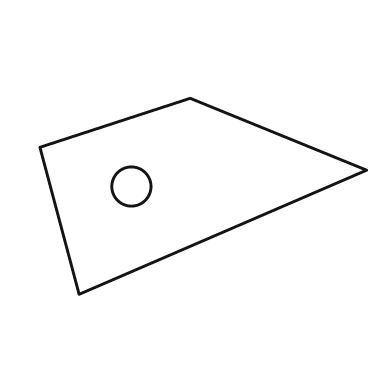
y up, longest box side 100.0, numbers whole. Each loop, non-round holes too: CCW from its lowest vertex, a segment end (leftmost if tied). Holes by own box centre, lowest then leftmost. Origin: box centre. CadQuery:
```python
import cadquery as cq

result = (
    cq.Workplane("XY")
    .moveTo(-38.0, -30.0)
    .lineTo(50.0, 8.0)
    .lineTo(-4.0, 30.0)
    .lineTo(-50.0, 15.0)
    .close()
    .moveTo(-22.0, 3.0)
    .circle(6.0)
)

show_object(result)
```